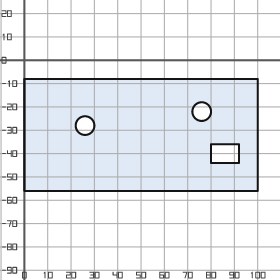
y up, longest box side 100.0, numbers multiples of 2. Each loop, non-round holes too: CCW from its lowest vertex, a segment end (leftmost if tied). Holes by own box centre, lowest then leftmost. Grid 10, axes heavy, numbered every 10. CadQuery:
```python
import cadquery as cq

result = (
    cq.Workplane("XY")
    .moveTo(0.0, -56.0)
    .lineTo(100.0, -56.0)
    .lineTo(100.0, -8.0)
    .lineTo(0.0, -8.0)
    .close()
    .moveTo(80.0, -44.0)
    .lineTo(92.0, -44.0)
    .lineTo(92.0, -36.0)
    .lineTo(80.0, -36.0)
    .close()
    .moveTo(26.0, -28.0)
    .circle(4.0)
    .moveTo(76.0, -22.0)
    .circle(4.0)
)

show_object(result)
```